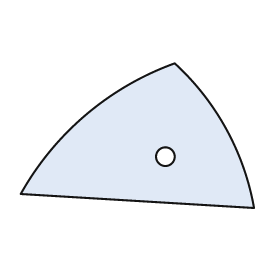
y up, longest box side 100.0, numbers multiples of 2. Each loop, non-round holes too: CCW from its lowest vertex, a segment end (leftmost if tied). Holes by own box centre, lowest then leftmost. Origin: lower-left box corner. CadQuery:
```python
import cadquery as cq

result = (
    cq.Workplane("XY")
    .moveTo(100.0, 0.0)
    .threePointArc((88.0, 34.0), (66.0, 62.0))
    .threePointArc((28.0, 40.0), (0.0, 6.0))
    .close()
    .moveTo(62.0, 22.0)
    .circle(4.0)
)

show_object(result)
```